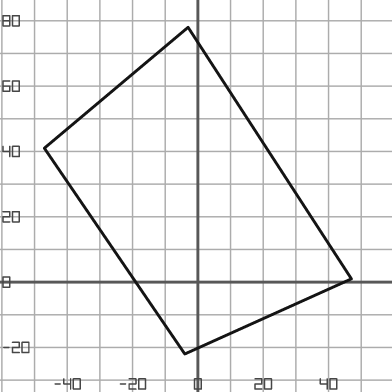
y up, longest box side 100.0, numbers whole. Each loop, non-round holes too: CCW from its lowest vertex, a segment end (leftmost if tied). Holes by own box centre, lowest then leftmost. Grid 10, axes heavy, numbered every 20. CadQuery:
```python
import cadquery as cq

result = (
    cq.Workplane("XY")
    .moveTo(-4.0, -22.0)
    .lineTo(47.0, 1.0)
    .lineTo(-3.0, 78.0)
    .lineTo(-47.0, 41.0)
    .close()
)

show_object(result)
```